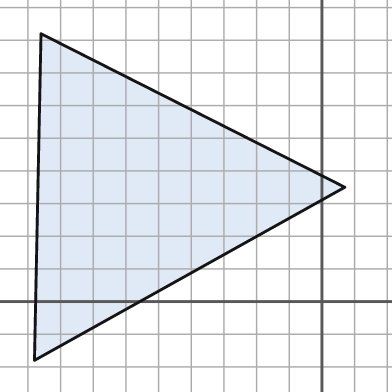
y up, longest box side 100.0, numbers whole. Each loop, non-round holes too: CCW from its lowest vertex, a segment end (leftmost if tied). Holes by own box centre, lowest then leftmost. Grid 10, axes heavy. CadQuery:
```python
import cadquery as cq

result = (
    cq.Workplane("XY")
    .moveTo(-88.0, -18.0)
    .lineTo(7.0, 35.0)
    .lineTo(-86.0, 82.0)
    .close()
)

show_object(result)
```